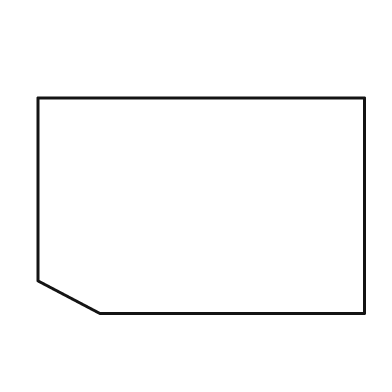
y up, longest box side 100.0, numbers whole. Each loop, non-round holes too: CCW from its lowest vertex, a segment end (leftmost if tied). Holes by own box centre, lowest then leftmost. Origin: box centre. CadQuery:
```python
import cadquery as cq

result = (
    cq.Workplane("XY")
    .moveTo(-31.0, -33.0)
    .lineTo(50.0, -33.0)
    .lineTo(50.0, 33.0)
    .lineTo(-50.0, 33.0)
    .lineTo(-50.0, -23.0)
    .close()
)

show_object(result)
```